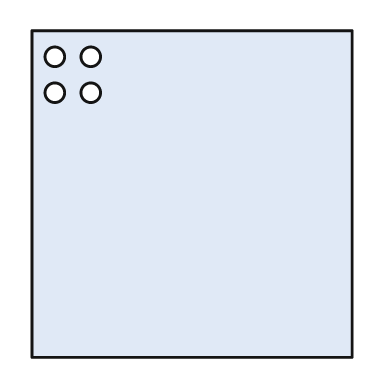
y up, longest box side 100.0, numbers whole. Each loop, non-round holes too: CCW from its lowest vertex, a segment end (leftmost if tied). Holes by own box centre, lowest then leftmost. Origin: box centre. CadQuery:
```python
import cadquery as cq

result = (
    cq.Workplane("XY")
    .moveTo(-49.0, -50.0)
    .lineTo(49.0, -50.0)
    .lineTo(49.0, 50.0)
    .lineTo(-49.0, 50.0)
    .close()
    .moveTo(-42.0, 31.0)
    .circle(3.0)
    .moveTo(-31.0, 31.0)
    .circle(3.0)
    .moveTo(-42.0, 42.0)
    .circle(3.0)
    .moveTo(-31.0, 42.0)
    .circle(3.0)
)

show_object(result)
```